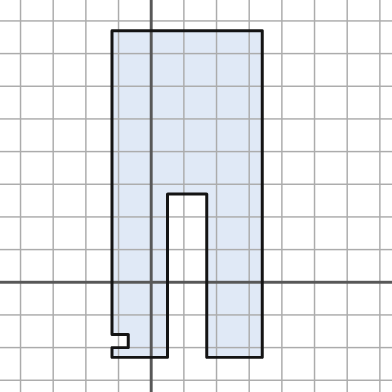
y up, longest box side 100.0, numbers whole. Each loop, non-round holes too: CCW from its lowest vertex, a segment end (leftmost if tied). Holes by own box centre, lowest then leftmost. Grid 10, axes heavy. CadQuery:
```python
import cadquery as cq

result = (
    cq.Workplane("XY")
    .moveTo(-12.0, -23.0)
    .lineTo(5.0, -23.0)
    .lineTo(5.0, 27.0)
    .lineTo(17.0, 27.0)
    .lineTo(17.0, -23.0)
    .lineTo(34.0, -23.0)
    .lineTo(34.0, 77.0)
    .lineTo(-12.0, 77.0)
    .lineTo(-12.0, -16.0)
    .lineTo(-7.0, -16.0)
    .lineTo(-7.0, -20.0)
    .lineTo(-12.0, -20.0)
    .close()
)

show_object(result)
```